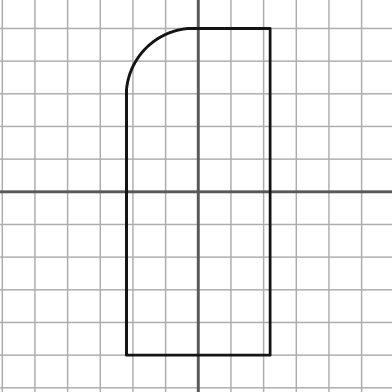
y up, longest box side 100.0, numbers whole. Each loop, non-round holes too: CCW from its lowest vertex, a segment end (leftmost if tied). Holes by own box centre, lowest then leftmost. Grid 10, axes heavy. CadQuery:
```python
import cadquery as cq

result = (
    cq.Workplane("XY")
    .moveTo(-22.0, -50.0)
    .lineTo(22.0, -50.0)
    .lineTo(22.0, 50.0)
    .lineTo(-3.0, 50.0)
    .threePointArc((-16.0, 44.0), (-22.0, 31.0))
    .close()
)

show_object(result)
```